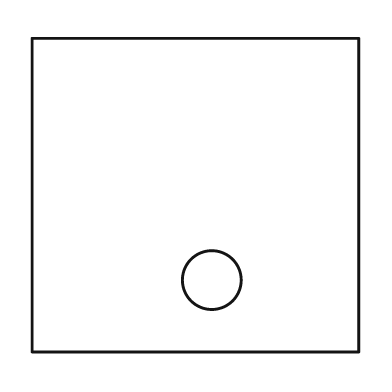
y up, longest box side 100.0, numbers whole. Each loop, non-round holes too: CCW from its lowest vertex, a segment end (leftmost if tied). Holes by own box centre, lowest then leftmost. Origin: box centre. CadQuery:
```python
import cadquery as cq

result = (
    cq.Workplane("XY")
    .moveTo(-50.0, -48.0)
    .lineTo(50.0, -48.0)
    .lineTo(50.0, 48.0)
    .lineTo(-50.0, 48.0)
    .close()
    .moveTo(5.0, -26.0)
    .circle(9.0)
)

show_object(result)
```